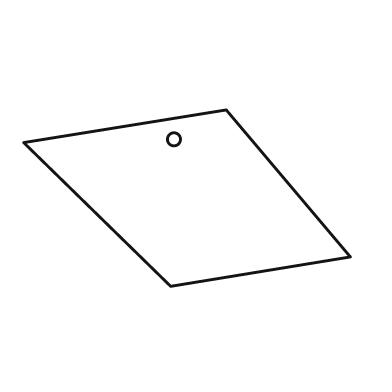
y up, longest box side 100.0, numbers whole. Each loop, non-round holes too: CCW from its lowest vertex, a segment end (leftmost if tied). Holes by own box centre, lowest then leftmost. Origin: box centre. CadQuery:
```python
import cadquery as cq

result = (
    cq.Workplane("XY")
    .moveTo(-5.0, -27.0)
    .lineTo(50.0, -18.0)
    .lineTo(12.0, 27.0)
    .lineTo(-50.0, 17.0)
    .close()
    .moveTo(-4.0, 18.0)
    .circle(2.0)
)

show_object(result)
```